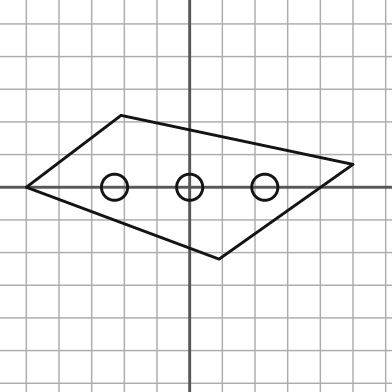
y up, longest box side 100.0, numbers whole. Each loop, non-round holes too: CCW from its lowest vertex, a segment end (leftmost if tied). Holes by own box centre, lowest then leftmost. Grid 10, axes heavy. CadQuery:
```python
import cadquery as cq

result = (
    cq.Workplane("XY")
    .moveTo(9.0, -22.0)
    .lineTo(50.0, 7.0)
    .lineTo(-21.0, 22.0)
    .lineTo(-50.0, 0.0)
    .close()
    .moveTo(-23.0, 0.0)
    .circle(4.0)
    .moveTo(0.0, 0.0)
    .circle(4.0)
    .moveTo(23.0, 0.0)
    .circle(4.0)
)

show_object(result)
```